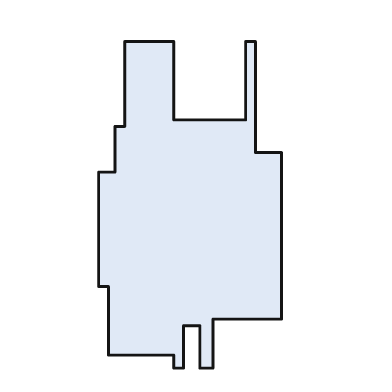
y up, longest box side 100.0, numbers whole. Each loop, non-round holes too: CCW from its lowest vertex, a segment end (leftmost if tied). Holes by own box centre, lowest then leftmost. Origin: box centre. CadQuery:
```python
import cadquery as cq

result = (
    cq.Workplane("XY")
    .moveTo(-5.0, -50.0)
    .lineTo(-2.0, -50.0)
    .lineTo(-2.0, -37.0)
    .lineTo(3.0, -37.0)
    .lineTo(3.0, -50.0)
    .lineTo(7.0, -50.0)
    .lineTo(7.0, -35.0)
    .lineTo(28.0, -35.0)
    .lineTo(28.0, 16.0)
    .lineTo(20.0, 16.0)
    .lineTo(20.0, 50.0)
    .lineTo(17.0, 50.0)
    .lineTo(17.0, 26.0)
    .lineTo(-5.0, 26.0)
    .lineTo(-5.0, 50.0)
    .lineTo(-20.0, 50.0)
    .lineTo(-20.0, 24.0)
    .lineTo(-23.0, 24.0)
    .lineTo(-23.0, 10.0)
    .lineTo(-28.0, 10.0)
    .lineTo(-28.0, -25.0)
    .lineTo(-25.0, -25.0)
    .lineTo(-25.0, -46.0)
    .lineTo(-5.0, -46.0)
    .close()
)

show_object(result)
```